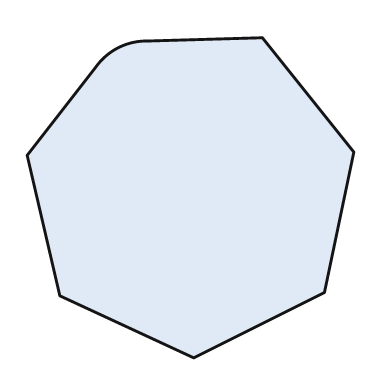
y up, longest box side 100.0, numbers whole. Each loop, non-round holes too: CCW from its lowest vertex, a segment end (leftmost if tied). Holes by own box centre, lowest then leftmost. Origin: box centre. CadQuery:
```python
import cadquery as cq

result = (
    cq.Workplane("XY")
    .moveTo(1.0, -49.0)
    .lineTo(41.0, -29.0)
    .lineTo(50.0, 14.0)
    .lineTo(22.0, 49.0)
    .lineTo(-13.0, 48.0)
    .threePointArc((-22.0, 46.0), (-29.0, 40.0))
    .lineTo(-50.0, 13.0)
    .lineTo(-40.0, -30.0)
    .close()
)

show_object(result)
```